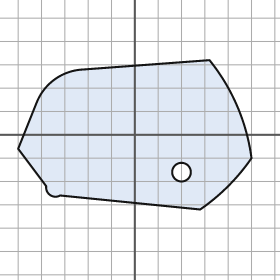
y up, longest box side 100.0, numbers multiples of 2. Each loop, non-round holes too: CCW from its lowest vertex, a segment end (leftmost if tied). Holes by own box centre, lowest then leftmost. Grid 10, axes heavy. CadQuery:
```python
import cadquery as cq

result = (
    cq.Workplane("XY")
    .moveTo(28.0, -32.0)
    .threePointArc((40.0, -22.0), (50.0, -10.0))
    .threePointArc((44.0, 12.0), (32.0, 32.0))
    .lineTo(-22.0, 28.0)
    .threePointArc((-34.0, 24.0), (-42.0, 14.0))
    .lineTo(-50.0, -6.0)
    .lineTo(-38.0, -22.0)
    .threePointArc((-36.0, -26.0), (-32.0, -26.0))
    .close()
    .moveTo(20.0, -16.0)
    .circle(4.0)
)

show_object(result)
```